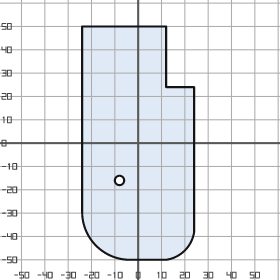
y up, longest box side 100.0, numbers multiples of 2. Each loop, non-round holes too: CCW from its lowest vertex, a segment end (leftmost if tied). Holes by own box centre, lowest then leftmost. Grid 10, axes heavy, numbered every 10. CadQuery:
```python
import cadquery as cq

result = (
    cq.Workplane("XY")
    .moveTo(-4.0, -50.0)
    .lineTo(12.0, -50.0)
    .threePointArc((20.0, -46.0), (24.0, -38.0))
    .lineTo(24.0, 24.0)
    .lineTo(12.0, 24.0)
    .lineTo(12.0, 50.0)
    .lineTo(-24.0, 50.0)
    .lineTo(-24.0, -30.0)
    .threePointArc((-18.0, -44.0), (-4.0, -50.0))
    .close()
    .moveTo(-8.0, -16.0)
    .circle(2.0)
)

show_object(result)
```